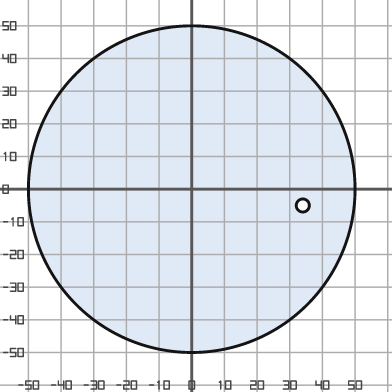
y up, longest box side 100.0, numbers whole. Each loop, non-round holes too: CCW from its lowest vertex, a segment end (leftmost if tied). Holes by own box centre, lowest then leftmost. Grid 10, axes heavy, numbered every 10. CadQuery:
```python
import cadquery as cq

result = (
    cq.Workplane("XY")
    .moveTo(0.0, 0.0)
    .circle(50.0)
    .moveTo(34.0, -5.0)
    .circle(2.0)
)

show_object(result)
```